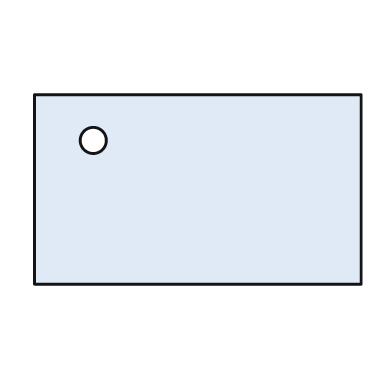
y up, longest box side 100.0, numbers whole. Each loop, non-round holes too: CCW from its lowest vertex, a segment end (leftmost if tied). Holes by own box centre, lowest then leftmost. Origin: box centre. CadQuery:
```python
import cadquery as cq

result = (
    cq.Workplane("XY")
    .moveTo(-50.0, -29.0)
    .lineTo(50.0, -29.0)
    .lineTo(50.0, 29.0)
    .lineTo(-50.0, 29.0)
    .close()
    .moveTo(-32.0, 15.0)
    .circle(4.0)
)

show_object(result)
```